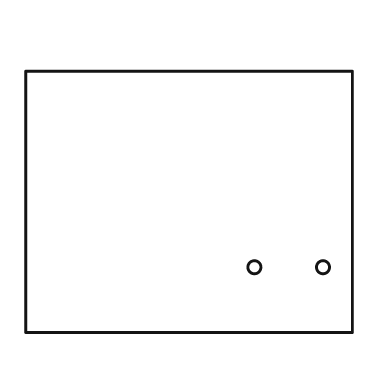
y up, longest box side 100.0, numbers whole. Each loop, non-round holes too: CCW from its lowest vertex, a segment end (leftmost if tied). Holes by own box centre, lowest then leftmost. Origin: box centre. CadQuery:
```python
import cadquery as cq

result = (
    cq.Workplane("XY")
    .moveTo(-50.0, -40.0)
    .lineTo(50.0, -40.0)
    .lineTo(50.0, 40.0)
    .lineTo(-50.0, 40.0)
    .close()
    .moveTo(20.0, -20.0)
    .circle(2.0)
    .moveTo(41.0, -20.0)
    .circle(2.0)
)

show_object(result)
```